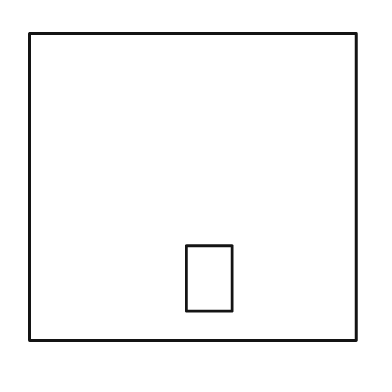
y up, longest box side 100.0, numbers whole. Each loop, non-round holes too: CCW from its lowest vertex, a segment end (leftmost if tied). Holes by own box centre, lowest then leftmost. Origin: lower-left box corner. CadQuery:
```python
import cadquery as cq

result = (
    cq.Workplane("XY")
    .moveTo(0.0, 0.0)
    .lineTo(100.0, 0.0)
    .lineTo(100.0, 94.0)
    .lineTo(0.0, 94.0)
    .close()
    .moveTo(48.0, 9.0)
    .lineTo(62.0, 9.0)
    .lineTo(62.0, 29.0)
    .lineTo(48.0, 29.0)
    .close()
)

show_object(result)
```